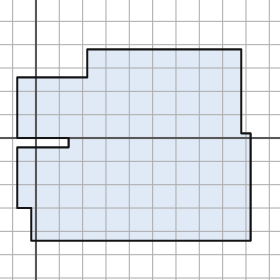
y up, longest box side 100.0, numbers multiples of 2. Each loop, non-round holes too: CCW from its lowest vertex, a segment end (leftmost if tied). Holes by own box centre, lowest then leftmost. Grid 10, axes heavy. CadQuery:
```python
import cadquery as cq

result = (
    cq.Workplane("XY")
    .moveTo(-2.0, -44.0)
    .lineTo(92.0, -44.0)
    .lineTo(92.0, 2.0)
    .lineTo(88.0, 2.0)
    .lineTo(88.0, 38.0)
    .lineTo(22.0, 38.0)
    .lineTo(22.0, 26.0)
    .lineTo(-8.0, 26.0)
    .lineTo(-8.0, 0.0)
    .lineTo(14.0, 0.0)
    .lineTo(14.0, -4.0)
    .lineTo(-8.0, -4.0)
    .lineTo(-8.0, -30.0)
    .lineTo(-2.0, -30.0)
    .close()
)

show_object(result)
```